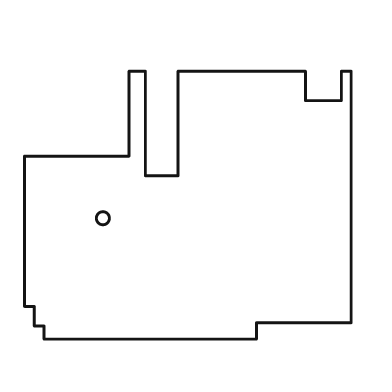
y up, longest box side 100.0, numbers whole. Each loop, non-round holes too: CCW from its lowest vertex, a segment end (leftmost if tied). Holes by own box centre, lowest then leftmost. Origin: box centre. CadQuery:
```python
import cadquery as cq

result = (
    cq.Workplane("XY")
    .moveTo(-44.0, -41.0)
    .lineTo(21.0, -41.0)
    .lineTo(21.0, -36.0)
    .lineTo(50.0, -36.0)
    .lineTo(50.0, 41.0)
    .lineTo(47.0, 41.0)
    .lineTo(47.0, 32.0)
    .lineTo(36.0, 32.0)
    .lineTo(36.0, 41.0)
    .lineTo(-3.0, 41.0)
    .lineTo(-3.0, 9.0)
    .lineTo(-13.0, 9.0)
    .lineTo(-13.0, 41.0)
    .lineTo(-18.0, 41.0)
    .lineTo(-18.0, 15.0)
    .lineTo(-50.0, 15.0)
    .lineTo(-50.0, -31.0)
    .lineTo(-47.0, -31.0)
    .lineTo(-47.0, -37.0)
    .lineTo(-44.0, -37.0)
    .close()
    .moveTo(-26.0, -4.0)
    .circle(2.0)
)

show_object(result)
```